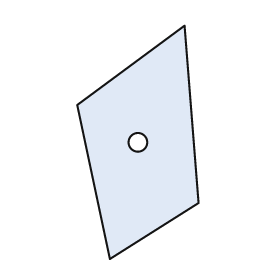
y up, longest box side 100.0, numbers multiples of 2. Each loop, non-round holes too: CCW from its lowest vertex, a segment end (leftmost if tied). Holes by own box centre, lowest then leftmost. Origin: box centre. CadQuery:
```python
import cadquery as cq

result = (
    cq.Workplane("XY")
    .moveTo(-12.0, -50.0)
    .lineTo(26.0, -26.0)
    .lineTo(20.0, 50.0)
    .lineTo(-26.0, 16.0)
    .close()
    .moveTo(0.0, 0.0)
    .circle(4.0)
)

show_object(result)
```